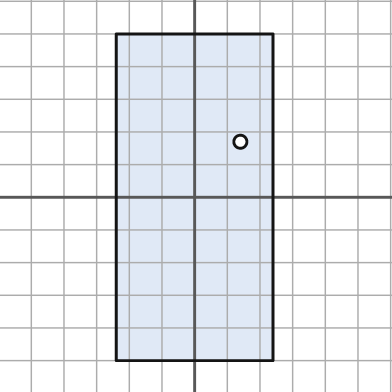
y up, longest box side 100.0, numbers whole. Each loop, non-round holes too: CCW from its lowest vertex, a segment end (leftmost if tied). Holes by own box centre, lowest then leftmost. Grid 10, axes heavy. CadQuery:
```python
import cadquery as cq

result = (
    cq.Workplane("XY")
    .moveTo(-24.0, -50.0)
    .lineTo(24.0, -50.0)
    .lineTo(24.0, 50.0)
    .lineTo(-24.0, 50.0)
    .close()
    .moveTo(14.0, 17.0)
    .circle(2.0)
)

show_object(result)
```